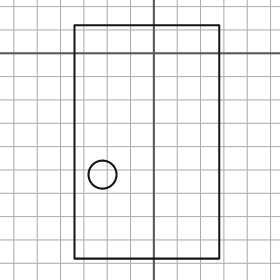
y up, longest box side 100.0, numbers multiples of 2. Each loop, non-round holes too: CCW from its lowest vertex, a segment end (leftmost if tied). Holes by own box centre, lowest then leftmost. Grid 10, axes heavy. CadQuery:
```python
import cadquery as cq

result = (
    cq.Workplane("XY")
    .moveTo(-34.0, -88.0)
    .lineTo(28.0, -88.0)
    .lineTo(28.0, 12.0)
    .lineTo(-34.0, 12.0)
    .close()
    .moveTo(-22.0, -52.0)
    .circle(6.0)
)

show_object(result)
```